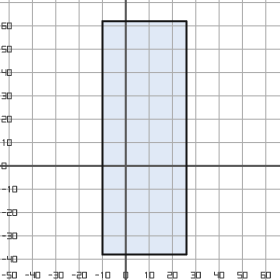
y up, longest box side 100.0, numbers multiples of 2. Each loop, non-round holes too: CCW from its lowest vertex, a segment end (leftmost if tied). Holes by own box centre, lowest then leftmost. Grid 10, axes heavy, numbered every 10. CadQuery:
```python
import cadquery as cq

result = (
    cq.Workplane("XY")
    .moveTo(-10.0, -38.0)
    .lineTo(26.0, -38.0)
    .lineTo(26.0, 62.0)
    .lineTo(-10.0, 62.0)
    .close()
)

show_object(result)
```